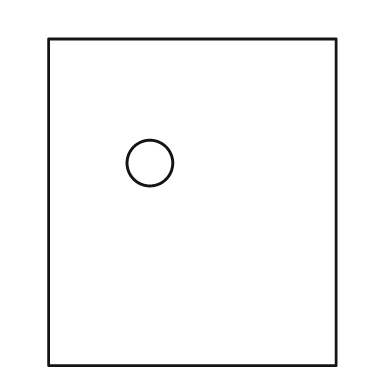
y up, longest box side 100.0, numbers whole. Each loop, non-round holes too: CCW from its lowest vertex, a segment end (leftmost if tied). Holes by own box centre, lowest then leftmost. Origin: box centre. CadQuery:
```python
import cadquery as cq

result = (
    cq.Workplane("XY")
    .moveTo(-44.0, -50.0)
    .lineTo(44.0, -50.0)
    .lineTo(44.0, 50.0)
    .lineTo(-44.0, 50.0)
    .close()
    .moveTo(-13.0, 12.0)
    .circle(7.0)
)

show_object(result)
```